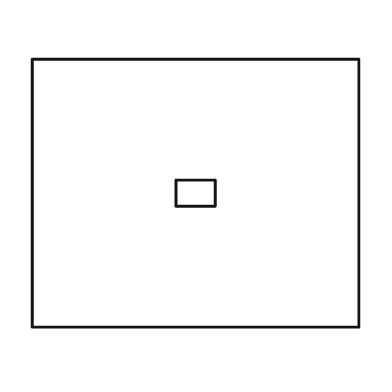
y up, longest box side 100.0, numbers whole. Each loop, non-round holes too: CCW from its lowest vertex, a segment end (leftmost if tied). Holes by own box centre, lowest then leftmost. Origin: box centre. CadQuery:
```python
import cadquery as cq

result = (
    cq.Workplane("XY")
    .moveTo(-50.0, -41.0)
    .lineTo(50.0, -41.0)
    .lineTo(50.0, 41.0)
    .lineTo(-50.0, 41.0)
    .close()
    .moveTo(-6.0, -4.0)
    .lineTo(6.0, -4.0)
    .lineTo(6.0, 4.0)
    .lineTo(-6.0, 4.0)
    .close()
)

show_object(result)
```